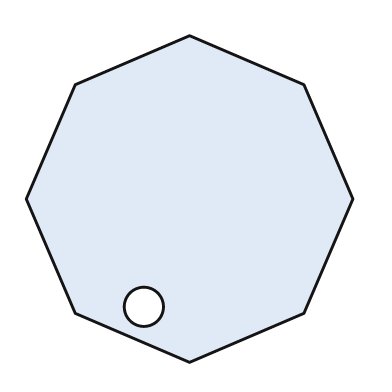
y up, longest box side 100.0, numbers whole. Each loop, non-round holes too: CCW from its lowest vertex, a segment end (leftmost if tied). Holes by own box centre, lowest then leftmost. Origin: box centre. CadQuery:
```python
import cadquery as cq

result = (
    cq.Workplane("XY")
    .moveTo(0.0, -50.0)
    .lineTo(35.0, -35.0)
    .lineTo(50.0, 0.0)
    .lineTo(35.0, 35.0)
    .lineTo(0.0, 50.0)
    .lineTo(-35.0, 35.0)
    .lineTo(-50.0, 0.0)
    .lineTo(-35.0, -35.0)
    .close()
    .moveTo(-14.0, -33.0)
    .circle(6.0)
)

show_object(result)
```